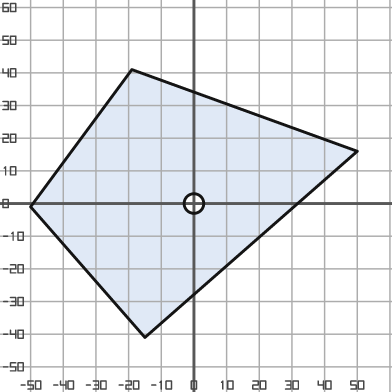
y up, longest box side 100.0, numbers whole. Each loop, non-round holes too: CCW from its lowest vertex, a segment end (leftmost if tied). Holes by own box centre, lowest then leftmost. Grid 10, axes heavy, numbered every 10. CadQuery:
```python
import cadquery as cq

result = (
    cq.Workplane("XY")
    .moveTo(-15.0, -41.0)
    .lineTo(50.0, 16.0)
    .lineTo(-19.0, 41.0)
    .lineTo(-50.0, -1.0)
    .close()
    .moveTo(0.0, 0.0)
    .circle(3.0)
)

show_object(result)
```